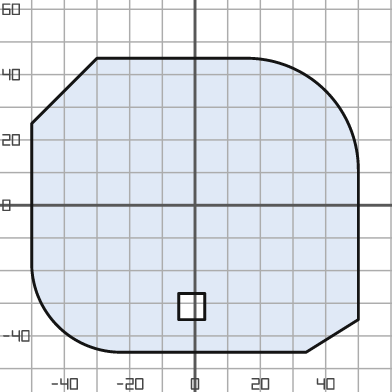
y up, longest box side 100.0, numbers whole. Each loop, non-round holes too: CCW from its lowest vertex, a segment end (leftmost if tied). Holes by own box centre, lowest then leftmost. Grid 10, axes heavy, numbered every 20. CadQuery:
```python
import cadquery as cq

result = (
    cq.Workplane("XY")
    .moveTo(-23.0, -45.0)
    .lineTo(34.0, -45.0)
    .lineTo(50.0, -35.0)
    .lineTo(50.0, 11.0)
    .threePointArc((40.0, 35.0), (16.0, 45.0))
    .lineTo(-30.0, 45.0)
    .lineTo(-50.0, 25.0)
    .lineTo(-50.0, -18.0)
    .threePointArc((-42.0, -37.0), (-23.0, -45.0))
    .close()
    .moveTo(-5.0, -35.0)
    .lineTo(3.0, -35.0)
    .lineTo(3.0, -27.0)
    .lineTo(-5.0, -27.0)
    .close()
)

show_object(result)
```